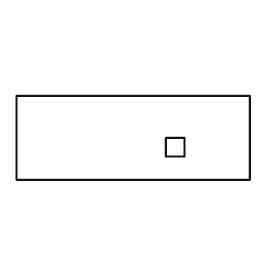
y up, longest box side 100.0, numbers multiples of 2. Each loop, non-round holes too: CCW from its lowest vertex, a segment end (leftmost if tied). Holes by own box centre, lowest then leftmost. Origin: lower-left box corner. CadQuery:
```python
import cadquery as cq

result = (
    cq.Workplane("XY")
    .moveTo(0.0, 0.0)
    .lineTo(100.0, 0.0)
    .lineTo(100.0, 36.0)
    .lineTo(0.0, 36.0)
    .close()
    .moveTo(64.0, 10.0)
    .lineTo(72.0, 10.0)
    .lineTo(72.0, 18.0)
    .lineTo(64.0, 18.0)
    .close()
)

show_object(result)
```